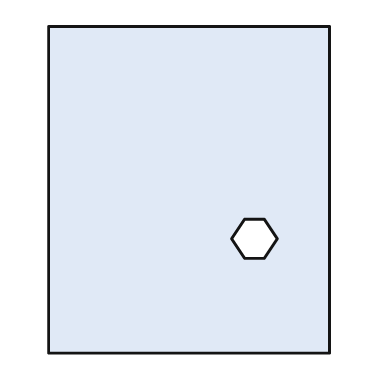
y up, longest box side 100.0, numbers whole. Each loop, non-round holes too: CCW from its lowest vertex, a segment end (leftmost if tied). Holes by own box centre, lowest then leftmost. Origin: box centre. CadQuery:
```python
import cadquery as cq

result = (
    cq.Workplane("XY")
    .moveTo(-43.0, -50.0)
    .lineTo(43.0, -50.0)
    .lineTo(43.0, 50.0)
    .lineTo(-43.0, 50.0)
    .close()
    .moveTo(17.0, -21.0)
    .lineTo(23.0, -21.0)
    .lineTo(27.0, -15.0)
    .lineTo(23.0, -9.0)
    .lineTo(17.0, -9.0)
    .lineTo(13.0, -15.0)
    .close()
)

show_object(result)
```